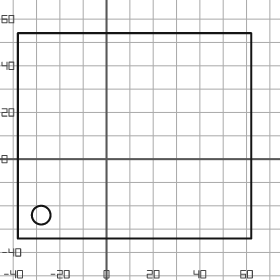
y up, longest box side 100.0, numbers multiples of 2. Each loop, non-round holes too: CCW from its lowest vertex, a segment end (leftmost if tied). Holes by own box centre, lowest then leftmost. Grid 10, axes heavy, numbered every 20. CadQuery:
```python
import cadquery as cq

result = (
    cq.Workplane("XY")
    .moveTo(-38.0, -34.0)
    .lineTo(62.0, -34.0)
    .lineTo(62.0, 54.0)
    .lineTo(-38.0, 54.0)
    .close()
    .moveTo(-28.0, -24.0)
    .circle(4.0)
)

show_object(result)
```